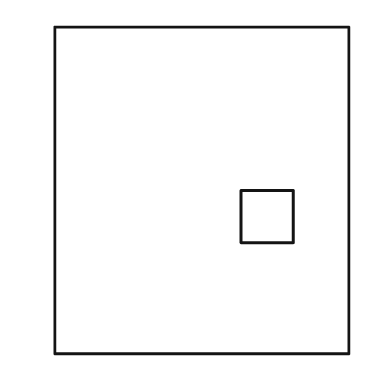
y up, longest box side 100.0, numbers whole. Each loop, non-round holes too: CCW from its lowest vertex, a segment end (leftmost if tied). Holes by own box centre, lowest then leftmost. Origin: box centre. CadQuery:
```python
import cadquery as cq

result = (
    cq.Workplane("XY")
    .moveTo(-45.0, -50.0)
    .lineTo(45.0, -50.0)
    .lineTo(45.0, 50.0)
    .lineTo(-45.0, 50.0)
    .close()
    .moveTo(12.0, -16.0)
    .lineTo(28.0, -16.0)
    .lineTo(28.0, 0.0)
    .lineTo(12.0, 0.0)
    .close()
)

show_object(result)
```